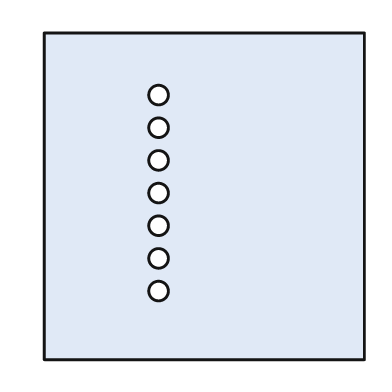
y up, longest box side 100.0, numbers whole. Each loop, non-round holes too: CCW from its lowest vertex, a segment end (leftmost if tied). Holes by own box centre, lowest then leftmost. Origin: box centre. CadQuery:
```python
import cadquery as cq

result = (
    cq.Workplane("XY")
    .moveTo(-49.0, -50.0)
    .lineTo(49.0, -50.0)
    .lineTo(49.0, 50.0)
    .lineTo(-49.0, 50.0)
    .close()
    .moveTo(-14.0, -29.0)
    .circle(3.0)
    .moveTo(-14.0, -19.0)
    .circle(3.0)
    .moveTo(-14.0, -9.0)
    .circle(3.0)
    .moveTo(-14.0, 1.0)
    .circle(3.0)
    .moveTo(-14.0, 11.0)
    .circle(3.0)
    .moveTo(-14.0, 21.0)
    .circle(3.0)
    .moveTo(-14.0, 31.0)
    .circle(3.0)
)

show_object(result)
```